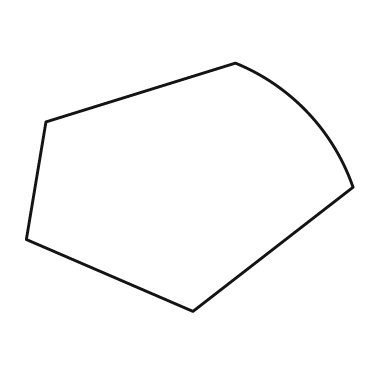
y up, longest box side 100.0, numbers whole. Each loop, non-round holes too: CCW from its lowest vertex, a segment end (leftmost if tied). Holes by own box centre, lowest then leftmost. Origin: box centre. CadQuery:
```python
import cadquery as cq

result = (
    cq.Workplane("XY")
    .moveTo(1.0, -38.0)
    .lineTo(50.0, 0.0)
    .threePointArc((36.0, 23.0), (14.0, 38.0))
    .lineTo(-44.0, 20.0)
    .lineTo(-50.0, -16.0)
    .close()
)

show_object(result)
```